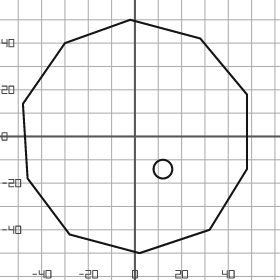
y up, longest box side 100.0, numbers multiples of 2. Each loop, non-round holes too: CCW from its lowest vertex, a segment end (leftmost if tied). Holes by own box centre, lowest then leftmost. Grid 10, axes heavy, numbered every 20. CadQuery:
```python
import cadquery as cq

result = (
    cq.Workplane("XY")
    .moveTo(2.0, -50.0)
    .lineTo(32.0, -40.0)
    .lineTo(48.0, -14.0)
    .lineTo(48.0, 18.0)
    .lineTo(28.0, 42.0)
    .lineTo(-2.0, 50.0)
    .lineTo(-30.0, 40.0)
    .lineTo(-48.0, 14.0)
    .lineTo(-46.0, -18.0)
    .lineTo(-28.0, -42.0)
    .close()
    .moveTo(12.0, -14.0)
    .circle(4.0)
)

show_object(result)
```